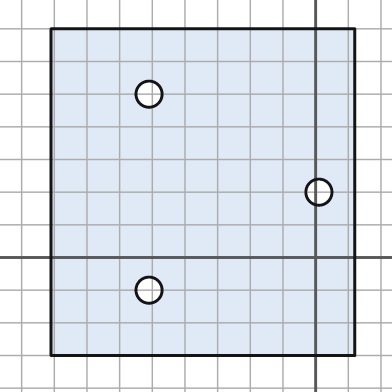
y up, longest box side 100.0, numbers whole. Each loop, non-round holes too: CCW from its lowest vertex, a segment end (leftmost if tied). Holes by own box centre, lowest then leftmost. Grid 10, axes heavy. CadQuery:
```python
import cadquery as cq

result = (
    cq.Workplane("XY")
    .moveTo(-81.0, -30.0)
    .lineTo(12.0, -30.0)
    .lineTo(12.0, 70.0)
    .lineTo(-81.0, 70.0)
    .close()
    .moveTo(-51.0, -10.0)
    .circle(4.0)
    .moveTo(1.0, 20.0)
    .circle(4.0)
    .moveTo(-51.0, 50.0)
    .circle(4.0)
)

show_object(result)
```